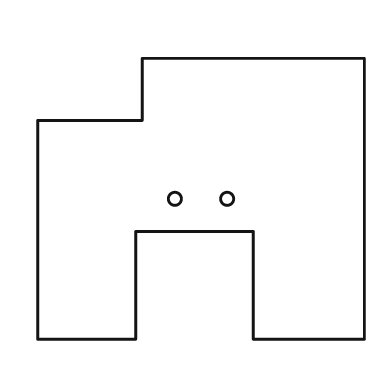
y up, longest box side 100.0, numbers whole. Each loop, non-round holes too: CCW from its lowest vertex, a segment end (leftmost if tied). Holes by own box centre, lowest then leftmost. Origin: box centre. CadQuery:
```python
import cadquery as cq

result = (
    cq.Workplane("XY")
    .moveTo(-50.0, -43.0)
    .lineTo(-20.0, -43.0)
    .lineTo(-20.0, -10.0)
    .lineTo(16.0, -10.0)
    .lineTo(16.0, -43.0)
    .lineTo(50.0, -43.0)
    .lineTo(50.0, 43.0)
    .lineTo(-18.0, 43.0)
    .lineTo(-18.0, 24.0)
    .lineTo(-50.0, 24.0)
    .close()
    .moveTo(-8.0, 0.0)
    .circle(2.0)
    .moveTo(8.0, 0.0)
    .circle(2.0)
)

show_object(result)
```